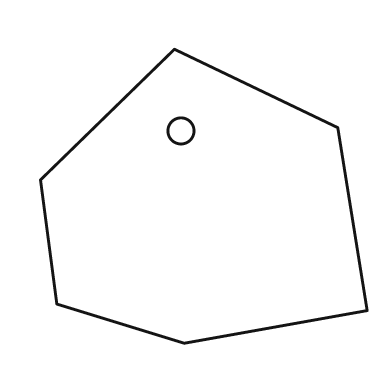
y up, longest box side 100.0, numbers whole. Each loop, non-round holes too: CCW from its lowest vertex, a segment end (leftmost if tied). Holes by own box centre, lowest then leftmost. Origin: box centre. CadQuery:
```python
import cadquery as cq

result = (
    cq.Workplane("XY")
    .moveTo(-6.0, -45.0)
    .lineTo(50.0, -35.0)
    .lineTo(41.0, 21.0)
    .lineTo(-9.0, 45.0)
    .lineTo(-50.0, 5.0)
    .lineTo(-45.0, -33.0)
    .close()
    .moveTo(-7.0, 20.0)
    .circle(4.0)
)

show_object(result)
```